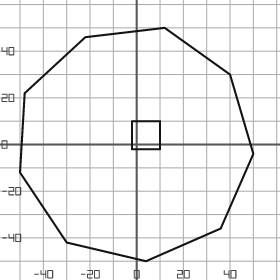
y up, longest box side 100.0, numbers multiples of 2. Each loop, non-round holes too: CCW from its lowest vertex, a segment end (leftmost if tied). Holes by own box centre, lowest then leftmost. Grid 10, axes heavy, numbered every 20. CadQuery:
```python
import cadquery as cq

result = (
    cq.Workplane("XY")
    .moveTo(4.0, -50.0)
    .lineTo(36.0, -36.0)
    .lineTo(50.0, -4.0)
    .lineTo(40.0, 30.0)
    .lineTo(12.0, 50.0)
    .lineTo(-22.0, 46.0)
    .lineTo(-48.0, 22.0)
    .lineTo(-50.0, -12.0)
    .lineTo(-30.0, -42.0)
    .close()
    .moveTo(-2.0, -2.0)
    .lineTo(10.0, -2.0)
    .lineTo(10.0, 10.0)
    .lineTo(-2.0, 10.0)
    .close()
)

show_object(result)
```